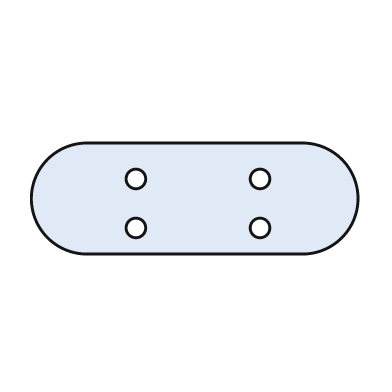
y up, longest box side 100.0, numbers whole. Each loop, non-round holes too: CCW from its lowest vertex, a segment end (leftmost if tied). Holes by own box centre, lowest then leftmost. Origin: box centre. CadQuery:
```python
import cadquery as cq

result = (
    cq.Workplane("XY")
    .moveTo(-33.0, -17.0)
    .lineTo(33.0, -17.0)
    .threePointArc((50.0, 0.0), (33.0, 17.0))
    .lineTo(-33.0, 17.0)
    .threePointArc((-50.0, 0.0), (-33.0, -17.0))
    .close()
    .moveTo(-18.0, -9.0)
    .circle(3.0)
    .moveTo(20.0, -9.0)
    .circle(3.0)
    .moveTo(-18.0, 6.0)
    .circle(3.0)
    .moveTo(20.0, 6.0)
    .circle(3.0)
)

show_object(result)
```